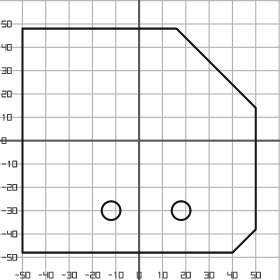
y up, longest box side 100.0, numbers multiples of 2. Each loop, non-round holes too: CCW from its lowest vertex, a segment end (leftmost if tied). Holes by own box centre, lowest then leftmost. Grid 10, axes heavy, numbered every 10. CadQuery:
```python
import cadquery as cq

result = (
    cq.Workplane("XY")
    .moveTo(-50.0, -48.0)
    .lineTo(40.0, -48.0)
    .lineTo(50.0, -38.0)
    .lineTo(50.0, 14.0)
    .lineTo(16.0, 48.0)
    .lineTo(-50.0, 48.0)
    .close()
    .moveTo(-12.0, -30.0)
    .circle(4.0)
    .moveTo(18.0, -30.0)
    .circle(4.0)
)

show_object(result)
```